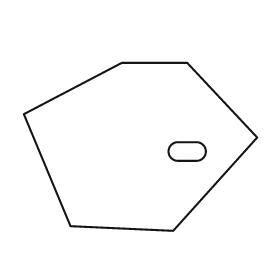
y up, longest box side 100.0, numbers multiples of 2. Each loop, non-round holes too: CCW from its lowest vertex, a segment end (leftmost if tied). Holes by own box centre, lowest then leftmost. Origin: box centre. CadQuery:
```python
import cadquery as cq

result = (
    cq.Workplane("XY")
    .moveTo(14.0, -36.0)
    .lineTo(50.0, 4.0)
    .lineTo(20.0, 36.0)
    .lineTo(-8.0, 36.0)
    .lineTo(-50.0, 14.0)
    .lineTo(-30.0, -34.0)
    .close()
    .moveTo(16.0, -6.0)
    .lineTo(24.0, -6.0)
    .threePointArc((28.0, -2.0), (24.0, 2.0))
    .lineTo(16.0, 2.0)
    .threePointArc((12.0, -2.0), (16.0, -6.0))
    .close()
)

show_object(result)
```